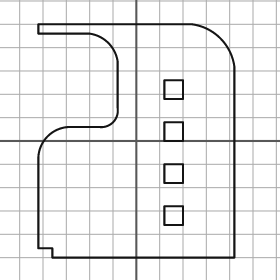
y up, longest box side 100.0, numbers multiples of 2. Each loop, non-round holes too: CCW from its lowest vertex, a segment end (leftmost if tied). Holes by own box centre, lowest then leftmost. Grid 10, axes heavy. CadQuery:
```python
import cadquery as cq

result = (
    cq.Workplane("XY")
    .moveTo(-36.0, -50.0)
    .lineTo(42.0, -50.0)
    .lineTo(42.0, 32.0)
    .threePointArc((36.0, 44.0), (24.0, 50.0))
    .lineTo(-42.0, 50.0)
    .lineTo(-42.0, 46.0)
    .lineTo(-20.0, 46.0)
    .threePointArc((-12.0, 42.0), (-8.0, 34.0))
    .lineTo(-8.0, 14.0)
    .threePointArc((-10.0, 8.0), (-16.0, 6.0))
    .lineTo(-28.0, 6.0)
    .threePointArc((-38.0, 2.0), (-42.0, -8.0))
    .lineTo(-42.0, -46.0)
    .lineTo(-36.0, -46.0)
    .close()
    .moveTo(12.0, -36.0)
    .lineTo(20.0, -36.0)
    .lineTo(20.0, -28.0)
    .lineTo(12.0, -28.0)
    .close()
    .moveTo(12.0, -18.0)
    .lineTo(20.0, -18.0)
    .lineTo(20.0, -10.0)
    .lineTo(12.0, -10.0)
    .close()
    .moveTo(12.0, 0.0)
    .lineTo(20.0, 0.0)
    .lineTo(20.0, 8.0)
    .lineTo(12.0, 8.0)
    .close()
    .moveTo(12.0, 18.0)
    .lineTo(20.0, 18.0)
    .lineTo(20.0, 26.0)
    .lineTo(12.0, 26.0)
    .close()
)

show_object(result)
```